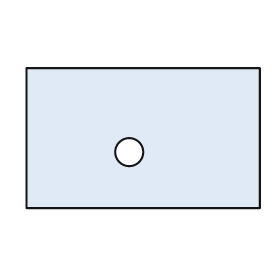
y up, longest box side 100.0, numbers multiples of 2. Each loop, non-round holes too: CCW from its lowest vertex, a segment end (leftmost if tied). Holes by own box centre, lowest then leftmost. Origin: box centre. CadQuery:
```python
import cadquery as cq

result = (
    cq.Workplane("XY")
    .moveTo(-50.0, -30.0)
    .lineTo(50.0, -30.0)
    .lineTo(50.0, 30.0)
    .lineTo(-50.0, 30.0)
    .close()
    .moveTo(-6.0, -6.0)
    .circle(6.0)
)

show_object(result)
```